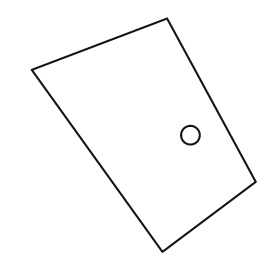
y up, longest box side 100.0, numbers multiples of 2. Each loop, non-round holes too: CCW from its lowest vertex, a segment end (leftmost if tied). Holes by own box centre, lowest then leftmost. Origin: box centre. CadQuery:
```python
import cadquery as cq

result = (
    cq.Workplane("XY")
    .moveTo(8.0, -50.0)
    .lineTo(48.0, -20.0)
    .lineTo(10.0, 50.0)
    .lineTo(-48.0, 28.0)
    .close()
    .moveTo(20.0, 0.0)
    .circle(4.0)
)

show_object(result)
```